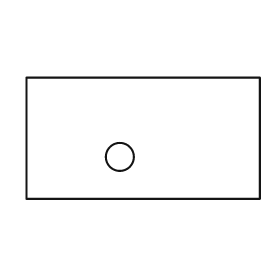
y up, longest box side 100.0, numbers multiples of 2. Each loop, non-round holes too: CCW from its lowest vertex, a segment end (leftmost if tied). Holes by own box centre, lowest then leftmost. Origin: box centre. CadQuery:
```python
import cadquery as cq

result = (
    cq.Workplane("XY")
    .moveTo(-50.0, -26.0)
    .lineTo(50.0, -26.0)
    .lineTo(50.0, 26.0)
    .lineTo(-50.0, 26.0)
    .close()
    .moveTo(-10.0, -8.0)
    .circle(6.0)
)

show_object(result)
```